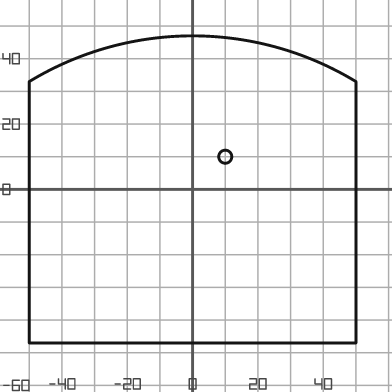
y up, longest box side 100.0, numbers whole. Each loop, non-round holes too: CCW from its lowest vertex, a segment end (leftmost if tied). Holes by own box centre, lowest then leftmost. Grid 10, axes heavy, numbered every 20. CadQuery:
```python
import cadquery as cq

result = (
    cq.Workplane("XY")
    .moveTo(-50.0, -47.0)
    .lineTo(50.0, -47.0)
    .lineTo(50.0, 33.0)
    .threePointArc((0.0, 47.0), (-50.0, 33.0))
    .close()
    .moveTo(10.0, 10.0)
    .circle(2.0)
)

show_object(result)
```